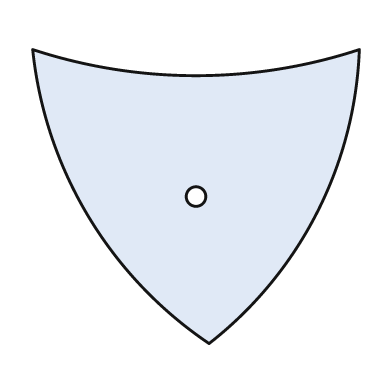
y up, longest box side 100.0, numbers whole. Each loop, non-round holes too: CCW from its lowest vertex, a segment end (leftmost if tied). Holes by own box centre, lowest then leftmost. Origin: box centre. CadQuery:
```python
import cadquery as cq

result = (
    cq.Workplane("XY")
    .moveTo(4.0, -45.0)
    .threePointArc((37.0, -5.0), (50.0, 45.0))
    .threePointArc((0.0, 37.0), (-50.0, 45.0))
    .threePointArc((-33.0, -6.0), (4.0, -45.0))
    .close()
    .moveTo(0.0, 0.0)
    .circle(3.0)
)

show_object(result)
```